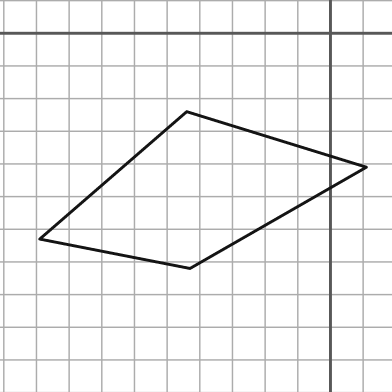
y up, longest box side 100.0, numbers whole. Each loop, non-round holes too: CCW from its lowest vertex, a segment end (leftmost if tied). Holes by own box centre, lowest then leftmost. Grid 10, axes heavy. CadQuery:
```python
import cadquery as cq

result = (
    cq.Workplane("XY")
    .moveTo(-43.0, -72.0)
    .lineTo(11.0, -41.0)
    .lineTo(-44.0, -24.0)
    .lineTo(-89.0, -63.0)
    .close()
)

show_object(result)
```